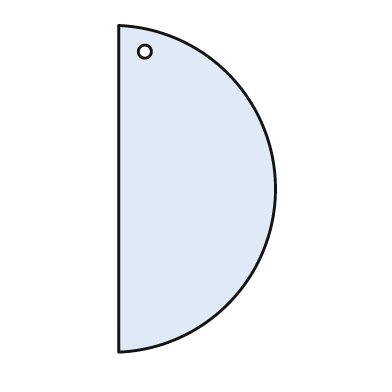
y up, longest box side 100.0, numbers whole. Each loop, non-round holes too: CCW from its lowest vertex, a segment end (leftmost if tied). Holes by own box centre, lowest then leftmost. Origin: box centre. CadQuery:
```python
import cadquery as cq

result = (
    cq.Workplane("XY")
    .moveTo(-24.0, -50.0)
    .threePointArc((24.0, 0.0), (-24.0, 50.0))
    .close()
    .moveTo(-16.0, 42.0)
    .circle(2.0)
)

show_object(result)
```